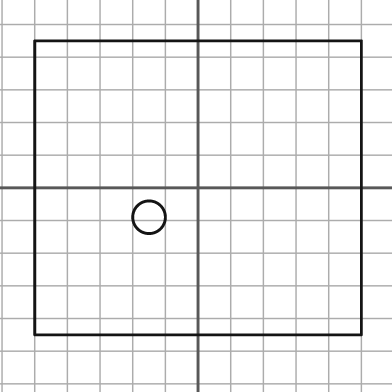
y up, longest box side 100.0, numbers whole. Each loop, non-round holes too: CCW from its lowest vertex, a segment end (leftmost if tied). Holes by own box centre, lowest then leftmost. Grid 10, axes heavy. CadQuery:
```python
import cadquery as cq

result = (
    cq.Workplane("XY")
    .moveTo(-50.0, -45.0)
    .lineTo(50.0, -45.0)
    .lineTo(50.0, 45.0)
    .lineTo(-50.0, 45.0)
    .close()
    .moveTo(-15.0, -9.0)
    .circle(5.0)
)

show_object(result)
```